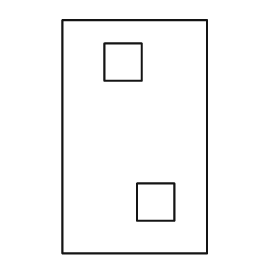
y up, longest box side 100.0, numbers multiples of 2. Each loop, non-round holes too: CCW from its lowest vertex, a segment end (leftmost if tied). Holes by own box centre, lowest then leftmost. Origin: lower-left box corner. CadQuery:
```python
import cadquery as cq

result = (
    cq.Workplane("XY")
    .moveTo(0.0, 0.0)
    .lineTo(62.0, 0.0)
    .lineTo(62.0, 100.0)
    .lineTo(0.0, 100.0)
    .close()
    .moveTo(32.0, 14.0)
    .lineTo(48.0, 14.0)
    .lineTo(48.0, 30.0)
    .lineTo(32.0, 30.0)
    .close()
    .moveTo(18.0, 74.0)
    .lineTo(34.0, 74.0)
    .lineTo(34.0, 90.0)
    .lineTo(18.0, 90.0)
    .close()
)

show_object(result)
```